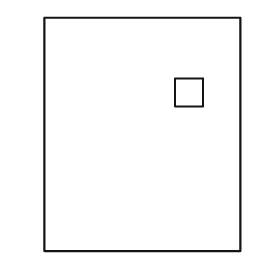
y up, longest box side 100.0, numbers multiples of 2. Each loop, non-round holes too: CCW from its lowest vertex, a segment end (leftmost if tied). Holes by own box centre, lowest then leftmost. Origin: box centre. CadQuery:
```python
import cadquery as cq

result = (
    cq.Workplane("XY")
    .moveTo(-42.0, -50.0)
    .lineTo(42.0, -50.0)
    .lineTo(42.0, 50.0)
    .lineTo(-42.0, 50.0)
    .close()
    .moveTo(14.0, 12.0)
    .lineTo(26.0, 12.0)
    .lineTo(26.0, 24.0)
    .lineTo(14.0, 24.0)
    .close()
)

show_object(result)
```